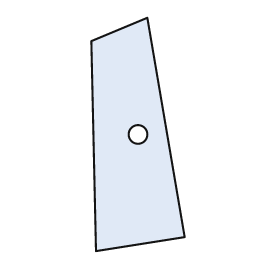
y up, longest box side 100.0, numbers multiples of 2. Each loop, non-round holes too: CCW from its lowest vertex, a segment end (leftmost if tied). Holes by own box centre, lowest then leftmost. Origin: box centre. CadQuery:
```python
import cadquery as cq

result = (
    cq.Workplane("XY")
    .moveTo(-18.0, -50.0)
    .lineTo(20.0, -44.0)
    .lineTo(4.0, 50.0)
    .lineTo(-20.0, 40.0)
    .close()
    .moveTo(0.0, 0.0)
    .circle(4.0)
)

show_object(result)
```